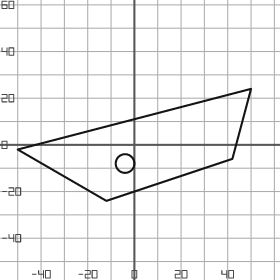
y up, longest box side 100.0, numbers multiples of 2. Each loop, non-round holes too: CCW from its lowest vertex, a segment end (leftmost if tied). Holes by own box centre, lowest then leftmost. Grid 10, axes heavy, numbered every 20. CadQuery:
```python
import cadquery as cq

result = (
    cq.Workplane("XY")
    .moveTo(-12.0, -24.0)
    .lineTo(42.0, -6.0)
    .lineTo(50.0, 24.0)
    .lineTo(-50.0, -2.0)
    .close()
    .moveTo(-4.0, -8.0)
    .circle(4.0)
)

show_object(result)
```